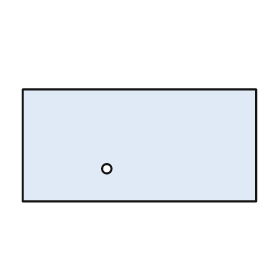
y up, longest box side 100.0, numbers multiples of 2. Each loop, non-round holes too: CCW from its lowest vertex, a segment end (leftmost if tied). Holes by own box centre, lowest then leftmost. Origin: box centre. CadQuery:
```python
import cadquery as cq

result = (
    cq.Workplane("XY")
    .moveTo(-50.0, -24.0)
    .lineTo(50.0, -24.0)
    .lineTo(50.0, 24.0)
    .lineTo(-50.0, 24.0)
    .close()
    .moveTo(-14.0, -10.0)
    .circle(2.0)
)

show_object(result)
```